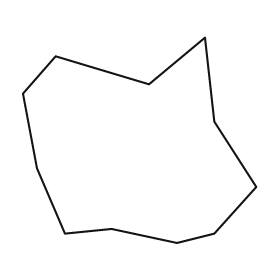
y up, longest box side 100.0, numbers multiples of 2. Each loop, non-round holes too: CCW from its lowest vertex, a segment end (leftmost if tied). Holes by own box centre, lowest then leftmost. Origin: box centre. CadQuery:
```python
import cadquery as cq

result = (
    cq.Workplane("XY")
    .moveTo(16.0, -44.0)
    .lineTo(32.0, -40.0)
    .lineTo(50.0, -20.0)
    .lineTo(32.0, 8.0)
    .lineTo(28.0, 44.0)
    .lineTo(4.0, 24.0)
    .lineTo(-36.0, 36.0)
    .lineTo(-50.0, 20.0)
    .lineTo(-44.0, -12.0)
    .lineTo(-32.0, -40.0)
    .lineTo(-12.0, -38.0)
    .close()
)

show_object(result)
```